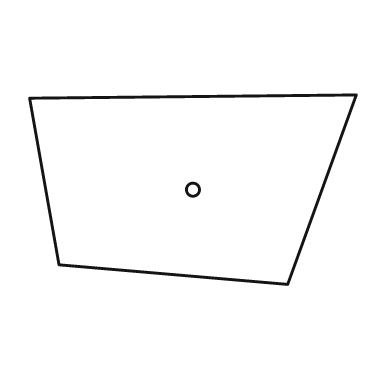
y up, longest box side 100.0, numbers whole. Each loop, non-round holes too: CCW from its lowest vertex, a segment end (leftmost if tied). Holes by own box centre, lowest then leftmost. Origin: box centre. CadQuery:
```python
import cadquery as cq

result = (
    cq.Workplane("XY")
    .moveTo(29.0, -29.0)
    .lineTo(50.0, 29.0)
    .lineTo(-50.0, 28.0)
    .lineTo(-41.0, -23.0)
    .close()
    .moveTo(0.0, 0.0)
    .circle(2.0)
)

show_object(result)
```